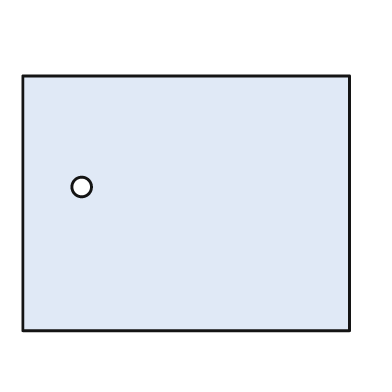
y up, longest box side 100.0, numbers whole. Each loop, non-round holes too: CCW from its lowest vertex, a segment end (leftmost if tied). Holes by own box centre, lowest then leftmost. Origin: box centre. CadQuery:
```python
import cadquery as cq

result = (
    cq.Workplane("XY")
    .moveTo(-50.0, -39.0)
    .lineTo(50.0, -39.0)
    .lineTo(50.0, 39.0)
    .lineTo(-50.0, 39.0)
    .close()
    .moveTo(-32.0, 5.0)
    .circle(3.0)
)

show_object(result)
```